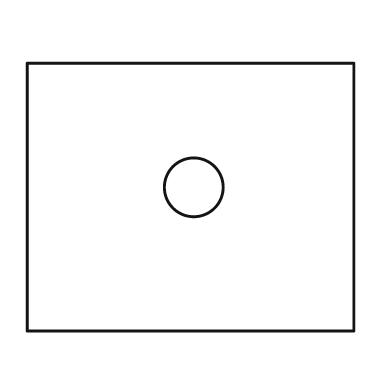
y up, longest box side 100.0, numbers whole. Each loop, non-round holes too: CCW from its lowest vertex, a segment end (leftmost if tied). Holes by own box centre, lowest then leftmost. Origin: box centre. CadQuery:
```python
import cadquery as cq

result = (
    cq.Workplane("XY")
    .moveTo(-50.0, -41.0)
    .lineTo(50.0, -41.0)
    .lineTo(50.0, 41.0)
    .lineTo(-50.0, 41.0)
    .close()
    .moveTo(1.0, 3.0)
    .circle(9.0)
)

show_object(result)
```